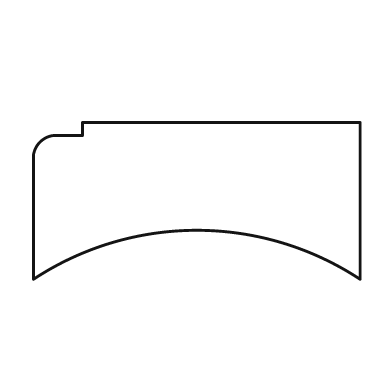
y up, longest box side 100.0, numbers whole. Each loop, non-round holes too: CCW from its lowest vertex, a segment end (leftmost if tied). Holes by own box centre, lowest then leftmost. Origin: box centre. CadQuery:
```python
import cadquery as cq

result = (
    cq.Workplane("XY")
    .moveTo(-50.0, -24.0)
    .threePointArc((0.0, -9.0), (50.0, -24.0))
    .lineTo(50.0, 24.0)
    .lineTo(-35.0, 24.0)
    .lineTo(-35.0, 20.0)
    .lineTo(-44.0, 20.0)
    .threePointArc((-48.0, 18.0), (-50.0, 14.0))
    .close()
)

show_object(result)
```